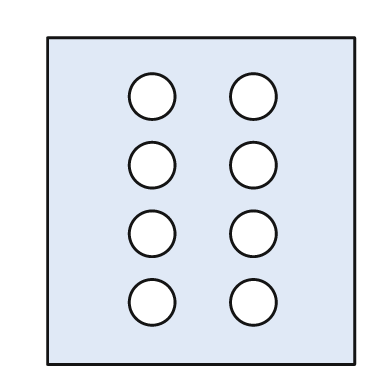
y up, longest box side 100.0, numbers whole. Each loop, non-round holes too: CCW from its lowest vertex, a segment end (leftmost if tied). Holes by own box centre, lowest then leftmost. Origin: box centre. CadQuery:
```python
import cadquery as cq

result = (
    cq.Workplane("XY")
    .moveTo(-47.0, -50.0)
    .lineTo(47.0, -50.0)
    .lineTo(47.0, 50.0)
    .lineTo(-47.0, 50.0)
    .close()
    .moveTo(-15.0, -31.0)
    .circle(7.0)
    .moveTo(16.0, -31.0)
    .circle(7.0)
    .moveTo(-15.0, -10.0)
    .circle(7.0)
    .moveTo(16.0, -10.0)
    .circle(7.0)
    .moveTo(-15.0, 11.0)
    .circle(7.0)
    .moveTo(16.0, 11.0)
    .circle(7.0)
    .moveTo(-15.0, 32.0)
    .circle(7.0)
    .moveTo(16.0, 32.0)
    .circle(7.0)
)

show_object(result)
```